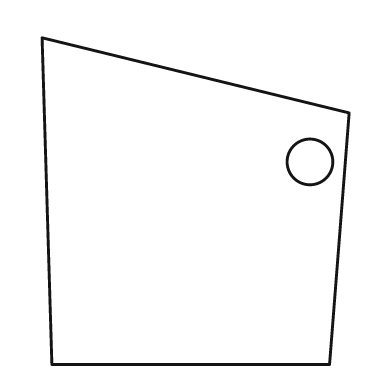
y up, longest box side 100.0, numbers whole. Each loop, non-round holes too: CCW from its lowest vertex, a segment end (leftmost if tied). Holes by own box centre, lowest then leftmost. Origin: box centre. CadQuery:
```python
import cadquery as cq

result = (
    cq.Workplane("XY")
    .moveTo(-44.0, -50.0)
    .lineTo(41.0, -50.0)
    .lineTo(47.0, 27.0)
    .lineTo(-47.0, 50.0)
    .close()
    .moveTo(35.0, 12.0)
    .circle(7.0)
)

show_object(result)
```